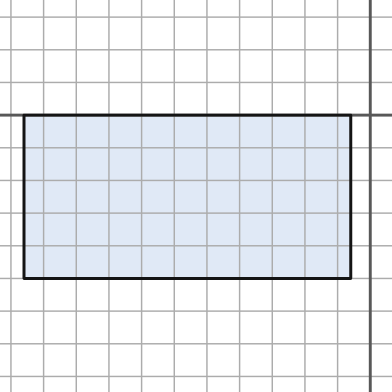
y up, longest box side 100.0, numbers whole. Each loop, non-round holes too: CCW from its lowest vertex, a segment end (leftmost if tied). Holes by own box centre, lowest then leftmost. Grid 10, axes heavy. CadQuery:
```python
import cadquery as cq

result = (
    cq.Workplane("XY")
    .moveTo(-106.0, -50.0)
    .lineTo(-6.0, -50.0)
    .lineTo(-6.0, 0.0)
    .lineTo(-106.0, 0.0)
    .close()
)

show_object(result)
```